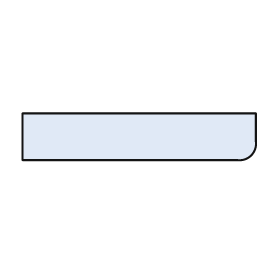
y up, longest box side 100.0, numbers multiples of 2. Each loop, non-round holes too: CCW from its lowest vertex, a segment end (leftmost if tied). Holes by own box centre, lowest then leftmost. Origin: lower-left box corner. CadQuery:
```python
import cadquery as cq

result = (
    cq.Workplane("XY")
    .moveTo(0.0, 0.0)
    .lineTo(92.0, 0.0)
    .threePointArc((98.0, 2.0), (100.0, 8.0))
    .lineTo(100.0, 20.0)
    .lineTo(0.0, 20.0)
    .close()
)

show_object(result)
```